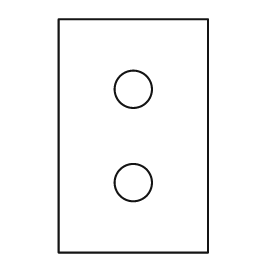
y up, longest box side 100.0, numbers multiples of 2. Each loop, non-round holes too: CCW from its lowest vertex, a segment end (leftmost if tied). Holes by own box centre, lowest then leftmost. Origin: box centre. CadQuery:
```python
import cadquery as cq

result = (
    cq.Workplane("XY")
    .moveTo(-32.0, -50.0)
    .lineTo(32.0, -50.0)
    .lineTo(32.0, 50.0)
    .lineTo(-32.0, 50.0)
    .close()
    .moveTo(0.0, -20.0)
    .circle(8.0)
    .moveTo(0.0, 20.0)
    .circle(8.0)
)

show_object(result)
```